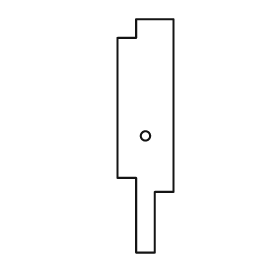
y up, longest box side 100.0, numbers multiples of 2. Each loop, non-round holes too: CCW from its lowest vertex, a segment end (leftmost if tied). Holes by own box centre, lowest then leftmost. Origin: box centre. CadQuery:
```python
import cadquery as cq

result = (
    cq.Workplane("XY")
    .moveTo(-4.0, -50.0)
    .lineTo(4.0, -50.0)
    .lineTo(4.0, -24.0)
    .lineTo(12.0, -24.0)
    .lineTo(12.0, 50.0)
    .lineTo(-4.0, 50.0)
    .lineTo(-4.0, 42.0)
    .lineTo(-12.0, 42.0)
    .lineTo(-12.0, -18.0)
    .lineTo(-4.0, -18.0)
    .close()
    .moveTo(0.0, 0.0)
    .circle(2.0)
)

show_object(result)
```